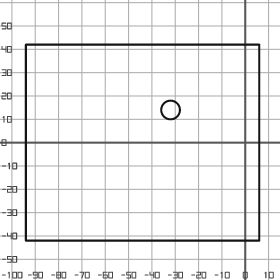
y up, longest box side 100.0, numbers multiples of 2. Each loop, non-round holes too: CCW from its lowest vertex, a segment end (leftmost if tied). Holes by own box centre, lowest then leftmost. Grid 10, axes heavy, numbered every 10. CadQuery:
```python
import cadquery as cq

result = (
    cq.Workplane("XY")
    .moveTo(-94.0, -42.0)
    .lineTo(6.0, -42.0)
    .lineTo(6.0, 42.0)
    .lineTo(-94.0, 42.0)
    .close()
    .moveTo(-32.0, 14.0)
    .circle(4.0)
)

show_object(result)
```